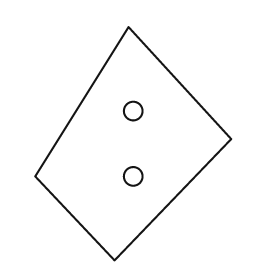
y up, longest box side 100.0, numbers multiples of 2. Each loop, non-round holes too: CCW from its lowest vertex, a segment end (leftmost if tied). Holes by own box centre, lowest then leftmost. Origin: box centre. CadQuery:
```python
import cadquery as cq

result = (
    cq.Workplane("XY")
    .moveTo(-8.0, -50.0)
    .lineTo(42.0, 2.0)
    .lineTo(-2.0, 50.0)
    .lineTo(-42.0, -14.0)
    .close()
    .moveTo(0.0, -14.0)
    .circle(4.0)
    .moveTo(0.0, 14.0)
    .circle(4.0)
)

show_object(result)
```